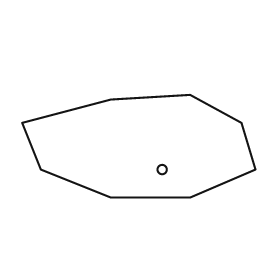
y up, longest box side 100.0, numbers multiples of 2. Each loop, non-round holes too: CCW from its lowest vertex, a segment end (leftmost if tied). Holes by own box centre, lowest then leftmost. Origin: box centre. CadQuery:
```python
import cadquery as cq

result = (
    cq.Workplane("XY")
    .moveTo(-12.0, -22.0)
    .lineTo(22.0, -22.0)
    .lineTo(50.0, -10.0)
    .lineTo(44.0, 10.0)
    .lineTo(22.0, 22.0)
    .lineTo(-12.0, 20.0)
    .lineTo(-50.0, 10.0)
    .lineTo(-42.0, -10.0)
    .close()
    .moveTo(10.0, -10.0)
    .circle(2.0)
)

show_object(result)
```